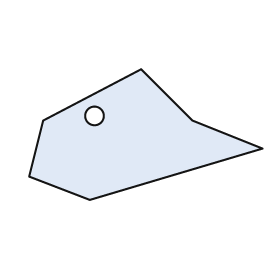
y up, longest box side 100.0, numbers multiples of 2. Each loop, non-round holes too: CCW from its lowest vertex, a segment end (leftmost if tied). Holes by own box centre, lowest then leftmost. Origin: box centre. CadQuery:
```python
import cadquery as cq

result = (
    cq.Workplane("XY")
    .moveTo(-24.0, -28.0)
    .lineTo(50.0, -6.0)
    .lineTo(20.0, 6.0)
    .lineTo(-2.0, 28.0)
    .lineTo(-44.0, 6.0)
    .lineTo(-50.0, -18.0)
    .close()
    .moveTo(-22.0, 8.0)
    .circle(4.0)
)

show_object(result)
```